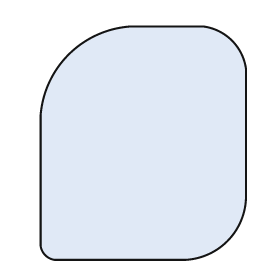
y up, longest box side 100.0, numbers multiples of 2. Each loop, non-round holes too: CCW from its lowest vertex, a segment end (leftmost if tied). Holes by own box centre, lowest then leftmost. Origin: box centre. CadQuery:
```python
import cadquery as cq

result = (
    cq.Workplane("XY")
    .moveTo(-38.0, -50.0)
    .lineTo(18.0, -50.0)
    .threePointArc((36.0, -42.0), (44.0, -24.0))
    .lineTo(44.0, 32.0)
    .threePointArc((38.0, 44.0), (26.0, 50.0))
    .lineTo(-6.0, 50.0)
    .threePointArc((-32.0, 38.0), (-44.0, 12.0))
    .lineTo(-44.0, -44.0)
    .threePointArc((-42.0, -48.0), (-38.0, -50.0))
    .close()
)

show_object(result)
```